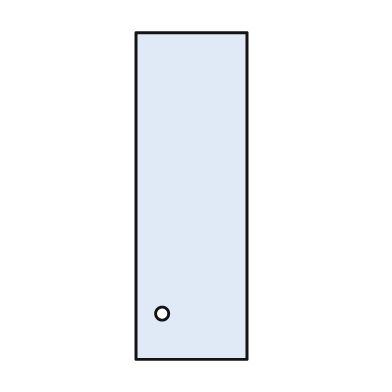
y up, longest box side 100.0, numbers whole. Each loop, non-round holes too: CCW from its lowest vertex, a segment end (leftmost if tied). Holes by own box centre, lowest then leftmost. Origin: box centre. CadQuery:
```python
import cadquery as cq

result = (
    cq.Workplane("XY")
    .moveTo(-17.0, -50.0)
    .lineTo(17.0, -50.0)
    .lineTo(17.0, 50.0)
    .lineTo(-17.0, 50.0)
    .close()
    .moveTo(-9.0, -36.0)
    .circle(2.0)
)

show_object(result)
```